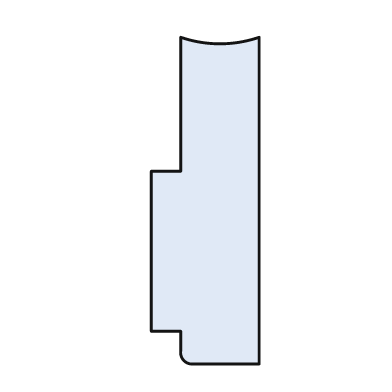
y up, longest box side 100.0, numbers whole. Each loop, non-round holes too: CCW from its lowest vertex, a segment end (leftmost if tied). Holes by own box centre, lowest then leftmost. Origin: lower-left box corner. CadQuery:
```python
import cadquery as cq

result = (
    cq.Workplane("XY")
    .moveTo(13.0, 0.0)
    .lineTo(33.0, 0.0)
    .lineTo(33.0, 100.0)
    .threePointArc((21.0, 98.0), (9.0, 100.0))
    .lineTo(9.0, 59.0)
    .lineTo(0.0, 59.0)
    .lineTo(0.0, 10.0)
    .lineTo(9.0, 10.0)
    .lineTo(9.0, 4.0)
    .threePointArc((10.0, 1.0), (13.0, 0.0))
    .close()
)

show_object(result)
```